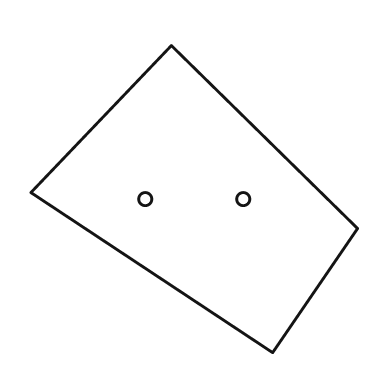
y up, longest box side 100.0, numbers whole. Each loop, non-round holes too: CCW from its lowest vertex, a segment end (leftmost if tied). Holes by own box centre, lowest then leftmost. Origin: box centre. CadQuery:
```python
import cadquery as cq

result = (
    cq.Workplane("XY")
    .moveTo(24.0, -47.0)
    .lineTo(50.0, -9.0)
    .lineTo(-7.0, 47.0)
    .lineTo(-50.0, 2.0)
    .close()
    .moveTo(-15.0, 0.0)
    .circle(2.0)
    .moveTo(15.0, 0.0)
    .circle(2.0)
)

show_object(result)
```